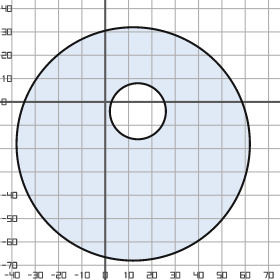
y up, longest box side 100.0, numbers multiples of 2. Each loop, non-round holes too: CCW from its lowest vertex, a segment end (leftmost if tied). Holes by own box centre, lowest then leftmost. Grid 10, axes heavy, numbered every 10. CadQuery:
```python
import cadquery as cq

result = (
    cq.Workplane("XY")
    .moveTo(12.0, -18.0)
    .circle(50.0)
    .moveTo(14.0, -4.0)
    .circle(12.0)
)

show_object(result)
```